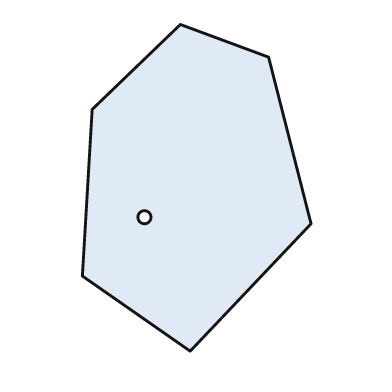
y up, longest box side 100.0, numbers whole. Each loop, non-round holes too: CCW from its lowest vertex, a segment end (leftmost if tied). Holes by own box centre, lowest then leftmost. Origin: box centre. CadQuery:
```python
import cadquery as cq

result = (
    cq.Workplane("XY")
    .moveTo(-2.0, -50.0)
    .lineTo(35.0, -11.0)
    .lineTo(22.0, 40.0)
    .lineTo(-5.0, 50.0)
    .lineTo(-32.0, 24.0)
    .lineTo(-35.0, -27.0)
    .close()
    .moveTo(-16.0, -9.0)
    .circle(2.0)
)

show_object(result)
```